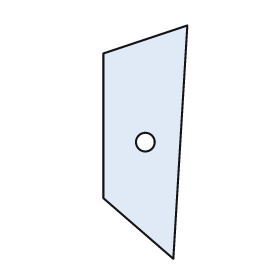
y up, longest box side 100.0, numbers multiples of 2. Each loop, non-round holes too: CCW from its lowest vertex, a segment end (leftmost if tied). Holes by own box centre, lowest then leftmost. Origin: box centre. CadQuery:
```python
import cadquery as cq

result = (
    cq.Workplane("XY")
    .moveTo(12.0, -50.0)
    .lineTo(18.0, 50.0)
    .lineTo(-18.0, 38.0)
    .lineTo(-18.0, -24.0)
    .close()
    .moveTo(0.0, 0.0)
    .circle(4.0)
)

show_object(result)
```